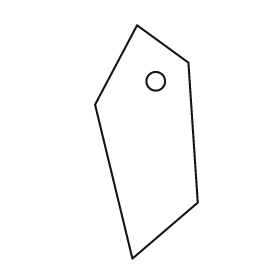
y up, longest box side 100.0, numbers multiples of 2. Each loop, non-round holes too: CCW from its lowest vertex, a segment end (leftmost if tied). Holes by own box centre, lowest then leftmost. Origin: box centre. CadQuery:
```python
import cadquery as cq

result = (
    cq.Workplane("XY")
    .moveTo(-6.0, -50.0)
    .lineTo(22.0, -26.0)
    .lineTo(18.0, 34.0)
    .lineTo(-4.0, 50.0)
    .lineTo(-22.0, 16.0)
    .close()
    .moveTo(4.0, 26.0)
    .circle(4.0)
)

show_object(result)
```